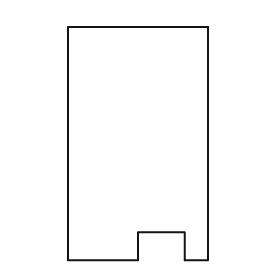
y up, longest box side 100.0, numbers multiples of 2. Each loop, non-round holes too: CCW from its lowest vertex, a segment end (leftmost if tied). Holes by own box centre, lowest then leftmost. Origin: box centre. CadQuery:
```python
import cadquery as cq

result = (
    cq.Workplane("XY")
    .moveTo(-30.0, -50.0)
    .lineTo(0.0, -50.0)
    .lineTo(0.0, -38.0)
    .lineTo(20.0, -38.0)
    .lineTo(20.0, -50.0)
    .lineTo(30.0, -50.0)
    .lineTo(30.0, 50.0)
    .lineTo(-30.0, 50.0)
    .close()
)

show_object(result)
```